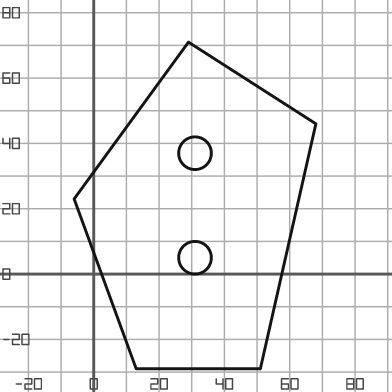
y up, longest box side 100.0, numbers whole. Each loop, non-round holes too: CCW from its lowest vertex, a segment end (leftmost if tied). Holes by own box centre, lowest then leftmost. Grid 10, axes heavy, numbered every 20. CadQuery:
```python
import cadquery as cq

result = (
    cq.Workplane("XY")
    .moveTo(13.0, -29.0)
    .lineTo(51.0, -29.0)
    .lineTo(68.0, 46.0)
    .lineTo(29.0, 71.0)
    .lineTo(-6.0, 23.0)
    .close()
    .moveTo(31.0, 5.0)
    .circle(5.0)
    .moveTo(31.0, 37.0)
    .circle(5.0)
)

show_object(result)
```